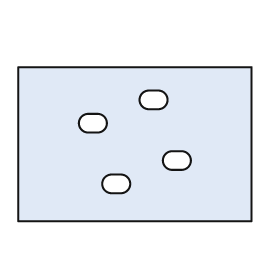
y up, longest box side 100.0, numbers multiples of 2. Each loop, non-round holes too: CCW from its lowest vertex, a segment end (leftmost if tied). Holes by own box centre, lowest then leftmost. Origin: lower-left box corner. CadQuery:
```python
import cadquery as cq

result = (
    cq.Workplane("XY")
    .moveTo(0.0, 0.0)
    .lineTo(100.0, 0.0)
    .lineTo(100.0, 66.0)
    .lineTo(0.0, 66.0)
    .close()
    .moveTo(40.0, 12.0)
    .lineTo(44.0, 12.0)
    .threePointArc((48.0, 16.0), (44.0, 20.0))
    .lineTo(40.0, 20.0)
    .threePointArc((36.0, 16.0), (40.0, 12.0))
    .close()
    .moveTo(66.0, 22.0)
    .lineTo(70.0, 22.0)
    .threePointArc((74.0, 26.0), (70.0, 30.0))
    .lineTo(66.0, 30.0)
    .threePointArc((62.0, 26.0), (66.0, 22.0))
    .close()
    .moveTo(30.0, 38.0)
    .lineTo(34.0, 38.0)
    .threePointArc((38.0, 42.0), (34.0, 46.0))
    .lineTo(30.0, 46.0)
    .threePointArc((26.0, 42.0), (30.0, 38.0))
    .close()
    .moveTo(56.0, 48.0)
    .lineTo(60.0, 48.0)
    .threePointArc((64.0, 52.0), (60.0, 56.0))
    .lineTo(56.0, 56.0)
    .threePointArc((52.0, 52.0), (56.0, 48.0))
    .close()
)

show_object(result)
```